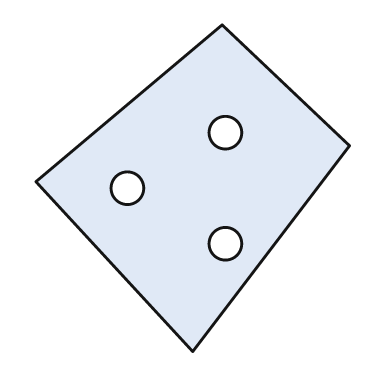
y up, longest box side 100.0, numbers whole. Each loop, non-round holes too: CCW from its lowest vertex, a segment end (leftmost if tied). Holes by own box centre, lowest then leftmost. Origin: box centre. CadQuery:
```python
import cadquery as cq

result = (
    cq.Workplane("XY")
    .moveTo(0.0, -50.0)
    .lineTo(48.0, 13.0)
    .lineTo(9.0, 50.0)
    .lineTo(-48.0, 2.0)
    .close()
    .moveTo(10.0, -17.0)
    .circle(5.0)
    .moveTo(-20.0, 0.0)
    .circle(5.0)
    .moveTo(10.0, 17.0)
    .circle(5.0)
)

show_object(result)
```